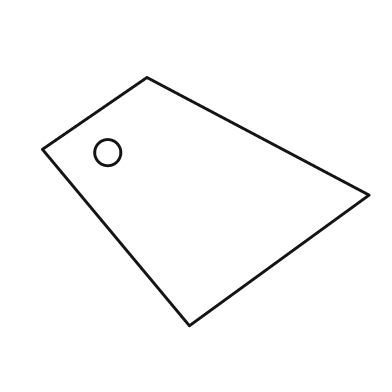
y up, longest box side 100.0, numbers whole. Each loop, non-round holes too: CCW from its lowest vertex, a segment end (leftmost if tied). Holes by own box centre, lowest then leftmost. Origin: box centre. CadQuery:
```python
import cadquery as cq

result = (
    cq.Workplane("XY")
    .moveTo(-5.0, -38.0)
    .lineTo(50.0, 2.0)
    .lineTo(-18.0, 38.0)
    .lineTo(-50.0, 16.0)
    .close()
    .moveTo(-30.0, 15.0)
    .circle(4.0)
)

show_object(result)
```